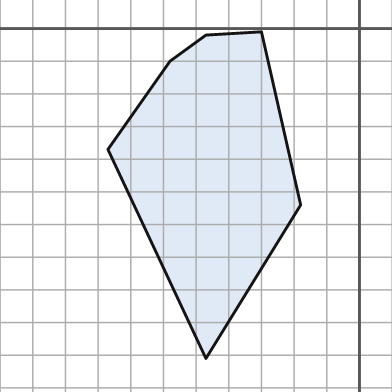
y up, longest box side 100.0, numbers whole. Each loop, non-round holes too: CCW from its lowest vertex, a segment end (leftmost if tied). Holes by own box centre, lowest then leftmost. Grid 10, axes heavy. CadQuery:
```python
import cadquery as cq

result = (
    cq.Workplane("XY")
    .moveTo(-47.0, -101.0)
    .lineTo(-18.0, -54.0)
    .lineTo(-30.0, -1.0)
    .lineTo(-47.0, -2.0)
    .lineTo(-58.0, -10.0)
    .lineTo(-77.0, -37.0)
    .close()
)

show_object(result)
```